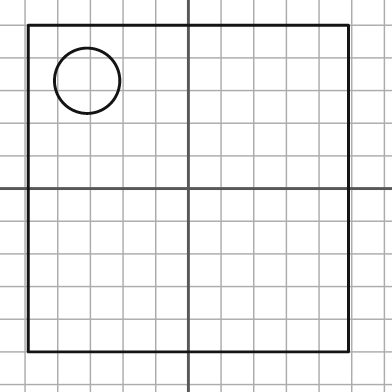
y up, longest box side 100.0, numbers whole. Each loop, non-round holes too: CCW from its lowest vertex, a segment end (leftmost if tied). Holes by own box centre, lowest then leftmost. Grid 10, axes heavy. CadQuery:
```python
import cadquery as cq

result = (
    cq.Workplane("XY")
    .moveTo(-49.0, -50.0)
    .lineTo(49.0, -50.0)
    .lineTo(49.0, 50.0)
    .lineTo(-49.0, 50.0)
    .close()
    .moveTo(-31.0, 33.0)
    .circle(10.0)
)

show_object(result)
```